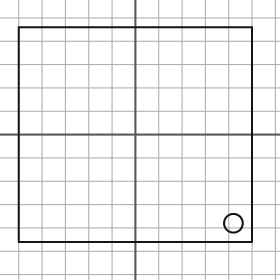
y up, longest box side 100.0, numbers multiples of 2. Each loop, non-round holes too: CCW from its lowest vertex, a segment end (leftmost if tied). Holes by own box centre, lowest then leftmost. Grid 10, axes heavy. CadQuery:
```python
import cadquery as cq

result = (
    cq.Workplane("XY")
    .moveTo(-50.0, -46.0)
    .lineTo(50.0, -46.0)
    .lineTo(50.0, 46.0)
    .lineTo(-50.0, 46.0)
    .close()
    .moveTo(42.0, -38.0)
    .circle(4.0)
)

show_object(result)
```